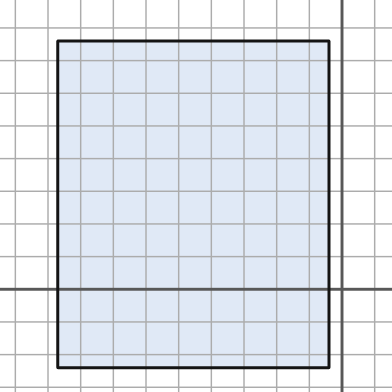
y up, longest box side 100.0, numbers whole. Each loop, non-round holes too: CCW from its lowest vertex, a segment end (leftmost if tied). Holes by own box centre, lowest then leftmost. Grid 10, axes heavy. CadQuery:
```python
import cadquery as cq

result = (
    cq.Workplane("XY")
    .moveTo(-87.0, -24.0)
    .lineTo(-4.0, -24.0)
    .lineTo(-4.0, 76.0)
    .lineTo(-87.0, 76.0)
    .close()
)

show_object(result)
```